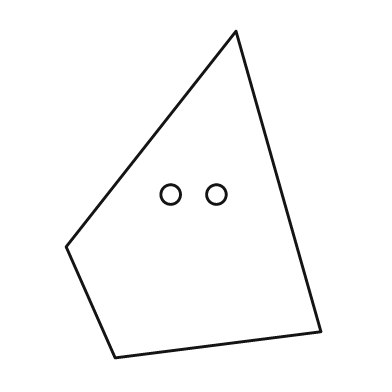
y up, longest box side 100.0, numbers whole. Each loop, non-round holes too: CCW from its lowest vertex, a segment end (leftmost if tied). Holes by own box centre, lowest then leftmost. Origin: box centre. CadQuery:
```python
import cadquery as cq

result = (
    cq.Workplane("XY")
    .moveTo(-24.0, -50.0)
    .lineTo(39.0, -42.0)
    .lineTo(13.0, 50.0)
    .lineTo(-39.0, -16.0)
    .close()
    .moveTo(-7.0, 0.0)
    .circle(3.0)
    .moveTo(7.0, 0.0)
    .circle(3.0)
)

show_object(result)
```